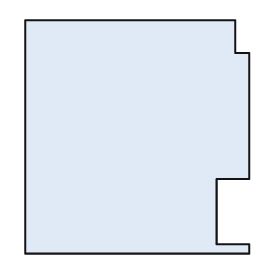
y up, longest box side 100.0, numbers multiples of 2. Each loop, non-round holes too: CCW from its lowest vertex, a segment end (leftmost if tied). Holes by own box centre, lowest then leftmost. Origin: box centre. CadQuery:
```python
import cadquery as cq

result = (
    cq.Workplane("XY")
    .moveTo(-48.0, -50.0)
    .lineTo(48.0, -50.0)
    .lineTo(48.0, -46.0)
    .lineTo(34.0, -46.0)
    .lineTo(34.0, -18.0)
    .lineTo(48.0, -18.0)
    .lineTo(48.0, 36.0)
    .lineTo(42.0, 36.0)
    .lineTo(42.0, 50.0)
    .lineTo(-48.0, 50.0)
    .close()
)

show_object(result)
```